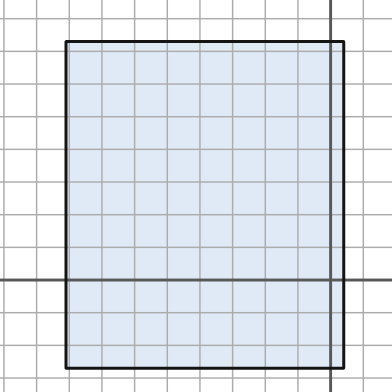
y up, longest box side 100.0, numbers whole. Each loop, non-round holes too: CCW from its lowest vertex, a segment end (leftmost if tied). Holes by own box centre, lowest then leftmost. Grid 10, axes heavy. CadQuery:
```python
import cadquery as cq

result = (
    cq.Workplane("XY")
    .moveTo(-81.0, -27.0)
    .lineTo(4.0, -27.0)
    .lineTo(4.0, 73.0)
    .lineTo(-81.0, 73.0)
    .close()
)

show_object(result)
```